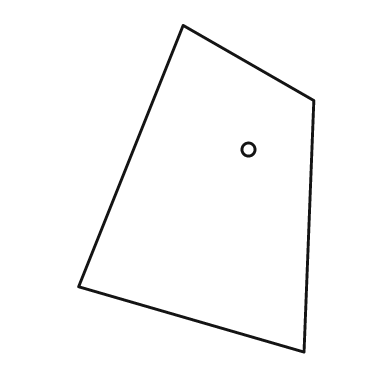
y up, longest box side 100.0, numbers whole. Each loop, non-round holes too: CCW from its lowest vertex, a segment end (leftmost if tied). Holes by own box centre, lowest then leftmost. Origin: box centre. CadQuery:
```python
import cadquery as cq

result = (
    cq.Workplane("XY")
    .moveTo(33.0, -50.0)
    .lineTo(36.0, 27.0)
    .lineTo(-4.0, 50.0)
    .lineTo(-36.0, -30.0)
    .close()
    .moveTo(16.0, 12.0)
    .circle(2.0)
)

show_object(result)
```